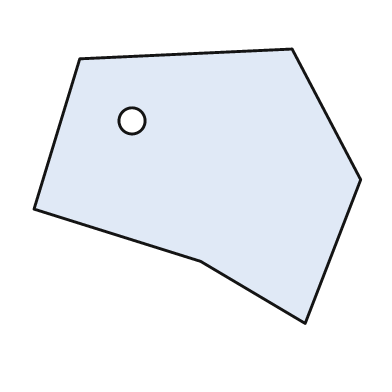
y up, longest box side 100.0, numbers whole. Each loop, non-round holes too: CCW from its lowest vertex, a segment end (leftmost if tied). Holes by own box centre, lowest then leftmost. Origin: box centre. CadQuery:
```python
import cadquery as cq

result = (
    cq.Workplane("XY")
    .moveTo(33.0, -42.0)
    .lineTo(50.0, 2.0)
    .lineTo(29.0, 42.0)
    .lineTo(-36.0, 39.0)
    .lineTo(-50.0, -7.0)
    .lineTo(1.0, -23.0)
    .close()
    .moveTo(-20.0, 20.0)
    .circle(4.0)
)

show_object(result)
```